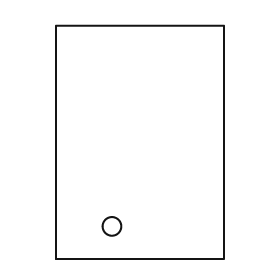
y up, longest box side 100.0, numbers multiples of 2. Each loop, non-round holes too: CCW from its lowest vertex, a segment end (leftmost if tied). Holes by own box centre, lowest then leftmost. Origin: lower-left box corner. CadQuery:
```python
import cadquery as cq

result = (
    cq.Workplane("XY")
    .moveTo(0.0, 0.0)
    .lineTo(72.0, 0.0)
    .lineTo(72.0, 100.0)
    .lineTo(0.0, 100.0)
    .close()
    .moveTo(24.0, 14.0)
    .circle(4.0)
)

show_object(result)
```